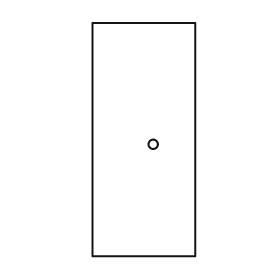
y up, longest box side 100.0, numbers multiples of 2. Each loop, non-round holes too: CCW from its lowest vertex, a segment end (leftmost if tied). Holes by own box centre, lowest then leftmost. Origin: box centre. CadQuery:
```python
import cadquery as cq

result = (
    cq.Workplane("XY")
    .moveTo(-22.0, -50.0)
    .lineTo(22.0, -50.0)
    .lineTo(22.0, 50.0)
    .lineTo(-22.0, 50.0)
    .close()
    .moveTo(4.0, -2.0)
    .circle(2.0)
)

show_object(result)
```